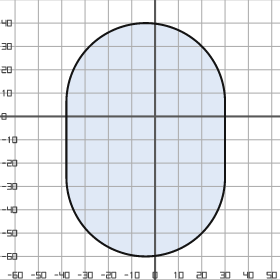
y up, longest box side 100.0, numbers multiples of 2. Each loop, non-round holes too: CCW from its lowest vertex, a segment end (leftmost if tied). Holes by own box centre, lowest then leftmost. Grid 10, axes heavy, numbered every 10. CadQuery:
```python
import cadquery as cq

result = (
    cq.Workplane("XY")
    .moveTo(-38.0, -26.0)
    .threePointArc((-4.0, -60.0), (30.0, -26.0))
    .lineTo(30.0, 6.0)
    .threePointArc((-4.0, 40.0), (-38.0, 6.0))
    .close()
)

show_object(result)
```